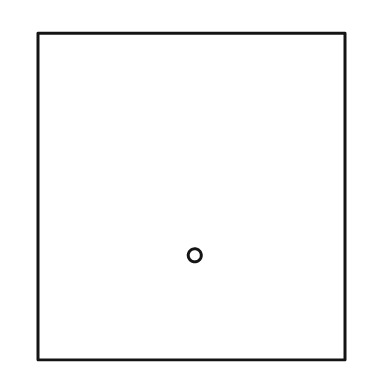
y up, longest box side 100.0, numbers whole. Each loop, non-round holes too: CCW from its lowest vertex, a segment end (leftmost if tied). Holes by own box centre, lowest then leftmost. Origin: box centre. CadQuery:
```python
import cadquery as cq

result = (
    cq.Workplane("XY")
    .moveTo(-47.0, -50.0)
    .lineTo(47.0, -50.0)
    .lineTo(47.0, 50.0)
    .lineTo(-47.0, 50.0)
    .close()
    .moveTo(1.0, -18.0)
    .circle(2.0)
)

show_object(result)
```